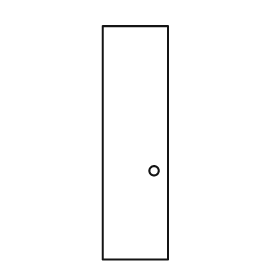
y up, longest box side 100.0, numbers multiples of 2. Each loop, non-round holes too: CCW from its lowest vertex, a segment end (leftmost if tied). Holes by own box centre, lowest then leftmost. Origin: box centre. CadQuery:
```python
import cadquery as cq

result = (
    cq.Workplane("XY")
    .moveTo(-14.0, -50.0)
    .lineTo(14.0, -50.0)
    .lineTo(14.0, 50.0)
    .lineTo(-14.0, 50.0)
    .close()
    .moveTo(8.0, -12.0)
    .circle(2.0)
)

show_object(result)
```